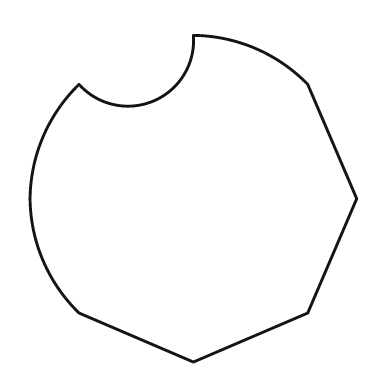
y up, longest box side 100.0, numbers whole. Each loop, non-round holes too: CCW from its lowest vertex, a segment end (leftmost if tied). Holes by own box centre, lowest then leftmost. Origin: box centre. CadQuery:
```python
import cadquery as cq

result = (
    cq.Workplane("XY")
    .moveTo(0.0, -50.0)
    .lineTo(35.0, -35.0)
    .lineTo(50.0, 0.0)
    .lineTo(35.0, 35.0)
    .threePointArc((19.0, 46.0), (0.0, 50.0))
    .threePointArc((-12.0, 30.0), (-35.0, 35.0))
    .threePointArc((-46.0, 19.0), (-50.0, 0.0))
    .threePointArc((-46.0, -19.0), (-35.0, -35.0))
    .close()
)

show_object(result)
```